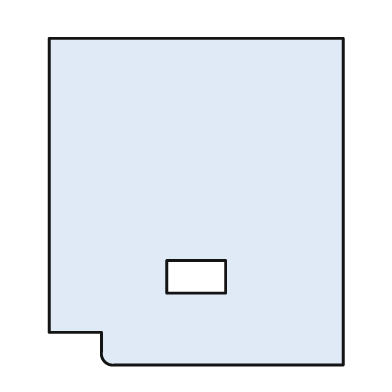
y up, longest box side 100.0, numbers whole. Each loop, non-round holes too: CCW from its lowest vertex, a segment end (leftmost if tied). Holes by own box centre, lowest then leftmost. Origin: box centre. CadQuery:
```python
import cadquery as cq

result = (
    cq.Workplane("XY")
    .moveTo(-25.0, -50.0)
    .lineTo(45.0, -50.0)
    .lineTo(45.0, 50.0)
    .lineTo(-45.0, 50.0)
    .lineTo(-45.0, -40.0)
    .lineTo(-29.0, -40.0)
    .lineTo(-29.0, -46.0)
    .threePointArc((-28.0, -49.0), (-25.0, -50.0))
    .close()
    .moveTo(-9.0, -28.0)
    .lineTo(9.0, -28.0)
    .lineTo(9.0, -18.0)
    .lineTo(-9.0, -18.0)
    .close()
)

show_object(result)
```